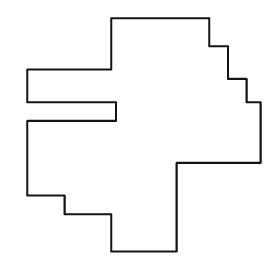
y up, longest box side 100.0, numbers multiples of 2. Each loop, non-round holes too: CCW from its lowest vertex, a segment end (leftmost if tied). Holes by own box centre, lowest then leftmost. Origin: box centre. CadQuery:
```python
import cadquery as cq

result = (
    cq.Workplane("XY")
    .moveTo(-14.0, -50.0)
    .lineTo(14.0, -50.0)
    .lineTo(14.0, -12.0)
    .lineTo(50.0, -12.0)
    .lineTo(50.0, 14.0)
    .lineTo(44.0, 14.0)
    .lineTo(44.0, 24.0)
    .lineTo(36.0, 24.0)
    .lineTo(36.0, 38.0)
    .lineTo(28.0, 38.0)
    .lineTo(28.0, 50.0)
    .lineTo(-14.0, 50.0)
    .lineTo(-14.0, 28.0)
    .lineTo(-50.0, 28.0)
    .lineTo(-50.0, 14.0)
    .lineTo(-12.0, 14.0)
    .lineTo(-12.0, 6.0)
    .lineTo(-50.0, 6.0)
    .lineTo(-50.0, -26.0)
    .lineTo(-34.0, -26.0)
    .lineTo(-34.0, -34.0)
    .lineTo(-14.0, -34.0)
    .close()
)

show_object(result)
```